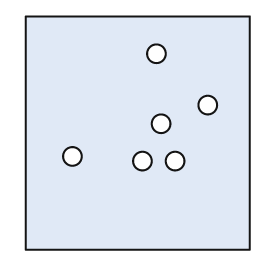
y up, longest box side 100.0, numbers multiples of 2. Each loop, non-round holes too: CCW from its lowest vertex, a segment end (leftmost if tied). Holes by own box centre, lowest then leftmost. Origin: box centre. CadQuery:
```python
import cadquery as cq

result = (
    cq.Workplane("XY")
    .moveTo(-48.0, -50.0)
    .lineTo(48.0, -50.0)
    .lineTo(48.0, 50.0)
    .lineTo(-48.0, 50.0)
    .close()
    .moveTo(2.0, -12.0)
    .circle(4.0)
    .moveTo(16.0, -12.0)
    .circle(4.0)
    .moveTo(-28.0, -10.0)
    .circle(4.0)
    .moveTo(10.0, 4.0)
    .circle(4.0)
    .moveTo(30.0, 12.0)
    .circle(4.0)
    .moveTo(8.0, 34.0)
    .circle(4.0)
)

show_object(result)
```